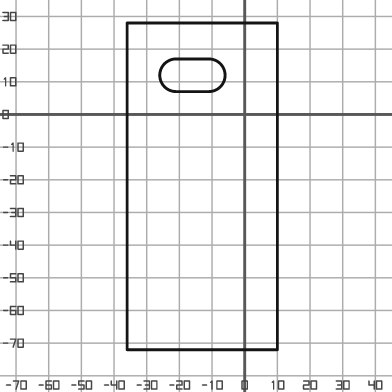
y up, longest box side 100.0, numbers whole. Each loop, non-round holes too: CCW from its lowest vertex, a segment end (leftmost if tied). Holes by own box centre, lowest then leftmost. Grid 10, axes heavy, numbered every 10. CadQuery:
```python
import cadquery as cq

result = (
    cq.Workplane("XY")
    .moveTo(-36.0, -72.0)
    .lineTo(10.0, -72.0)
    .lineTo(10.0, 28.0)
    .lineTo(-36.0, 28.0)
    .close()
    .moveTo(-21.0, 7.0)
    .lineTo(-11.0, 7.0)
    .threePointArc((-6.0, 12.0), (-11.0, 17.0))
    .lineTo(-21.0, 17.0)
    .threePointArc((-26.0, 12.0), (-21.0, 7.0))
    .close()
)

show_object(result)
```